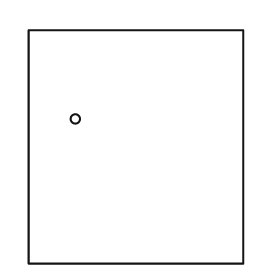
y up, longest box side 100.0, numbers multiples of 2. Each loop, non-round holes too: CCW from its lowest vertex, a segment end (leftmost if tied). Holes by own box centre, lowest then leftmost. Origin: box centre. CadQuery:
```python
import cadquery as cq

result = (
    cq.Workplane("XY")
    .moveTo(-46.0, -50.0)
    .lineTo(46.0, -50.0)
    .lineTo(46.0, 50.0)
    .lineTo(-46.0, 50.0)
    .close()
    .moveTo(-26.0, 12.0)
    .circle(2.0)
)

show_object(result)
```